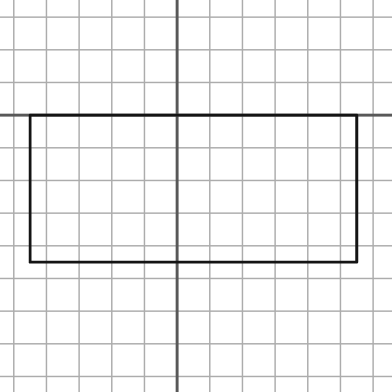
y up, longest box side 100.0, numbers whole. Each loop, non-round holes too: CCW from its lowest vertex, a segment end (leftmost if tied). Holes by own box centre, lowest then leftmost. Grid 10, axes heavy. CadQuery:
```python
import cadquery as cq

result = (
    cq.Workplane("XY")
    .moveTo(-45.0, -45.0)
    .lineTo(55.0, -45.0)
    .lineTo(55.0, 0.0)
    .lineTo(-45.0, 0.0)
    .close()
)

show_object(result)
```